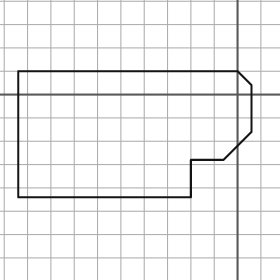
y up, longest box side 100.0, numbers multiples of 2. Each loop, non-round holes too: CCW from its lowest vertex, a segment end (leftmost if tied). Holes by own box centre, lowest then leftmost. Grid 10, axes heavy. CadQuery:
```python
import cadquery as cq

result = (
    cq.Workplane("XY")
    .moveTo(-94.0, -44.0)
    .lineTo(-20.0, -44.0)
    .lineTo(-20.0, -28.0)
    .lineTo(-6.0, -28.0)
    .lineTo(6.0, -16.0)
    .lineTo(6.0, 4.0)
    .lineTo(0.0, 10.0)
    .lineTo(-94.0, 10.0)
    .close()
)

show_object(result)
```